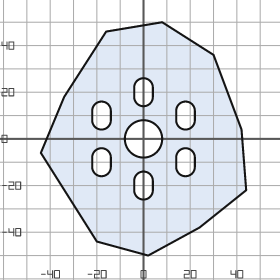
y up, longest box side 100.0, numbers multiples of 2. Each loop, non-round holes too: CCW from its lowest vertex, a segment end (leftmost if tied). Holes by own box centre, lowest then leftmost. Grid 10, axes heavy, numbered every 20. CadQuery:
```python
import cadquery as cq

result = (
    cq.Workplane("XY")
    .moveTo(2.0, -50.0)
    .lineTo(24.0, -38.0)
    .lineTo(44.0, -22.0)
    .lineTo(42.0, 4.0)
    .lineTo(30.0, 36.0)
    .lineTo(8.0, 50.0)
    .lineTo(-16.0, 46.0)
    .lineTo(-34.0, 18.0)
    .lineTo(-44.0, -6.0)
    .lineTo(-20.0, -44.0)
    .close()
    .moveTo(-4.0, -22.0)
    .threePointArc((0.0, -26.0), (4.0, -22.0))
    .lineTo(4.0, -18.0)
    .threePointArc((0.0, -14.0), (-4.0, -18.0))
    .close()
    .moveTo(-22.0, -12.0)
    .threePointArc((-18.0, -16.0), (-14.0, -12.0))
    .lineTo(-14.0, -8.0)
    .threePointArc((-18.0, -4.0), (-22.0, -8.0))
    .close()
    .moveTo(14.0, -12.0)
    .threePointArc((18.0, -16.0), (22.0, -12.0))
    .lineTo(22.0, -8.0)
    .threePointArc((18.0, -4.0), (14.0, -8.0))
    .close()
    .moveTo(0.0, 0.0)
    .circle(8.0)
    .moveTo(-22.0, 8.0)
    .threePointArc((-18.0, 4.0), (-14.0, 8.0))
    .lineTo(-14.0, 12.0)
    .threePointArc((-18.0, 16.0), (-22.0, 12.0))
    .close()
    .moveTo(14.0, 8.0)
    .threePointArc((18.0, 4.0), (22.0, 8.0))
    .lineTo(22.0, 12.0)
    .threePointArc((18.0, 16.0), (14.0, 12.0))
    .close()
    .moveTo(-4.0, 18.0)
    .threePointArc((0.0, 14.0), (4.0, 18.0))
    .lineTo(4.0, 22.0)
    .threePointArc((0.0, 26.0), (-4.0, 22.0))
    .close()
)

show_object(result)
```